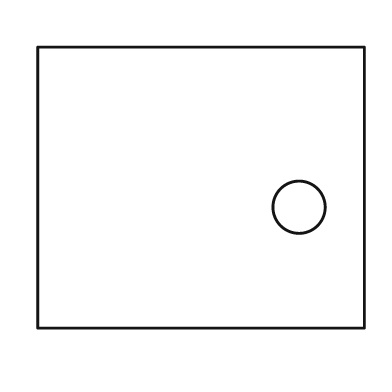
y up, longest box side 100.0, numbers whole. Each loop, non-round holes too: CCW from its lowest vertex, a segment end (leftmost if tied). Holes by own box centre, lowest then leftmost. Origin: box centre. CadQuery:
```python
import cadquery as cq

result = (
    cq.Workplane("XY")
    .moveTo(-50.0, -43.0)
    .lineTo(50.0, -43.0)
    .lineTo(50.0, 43.0)
    .lineTo(-50.0, 43.0)
    .close()
    .moveTo(30.0, -6.0)
    .circle(8.0)
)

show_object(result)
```